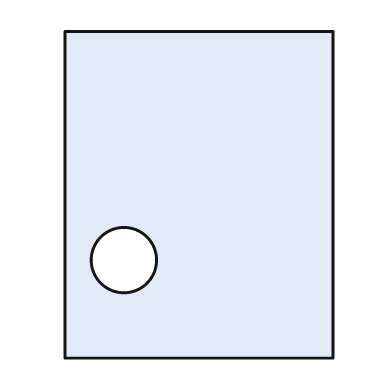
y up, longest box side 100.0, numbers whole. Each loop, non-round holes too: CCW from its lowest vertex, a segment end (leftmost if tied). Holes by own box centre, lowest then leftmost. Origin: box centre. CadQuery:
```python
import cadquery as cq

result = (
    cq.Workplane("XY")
    .moveTo(-41.0, -50.0)
    .lineTo(41.0, -50.0)
    .lineTo(41.0, 50.0)
    .lineTo(-41.0, 50.0)
    .close()
    .moveTo(-23.0, -20.0)
    .circle(10.0)
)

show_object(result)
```